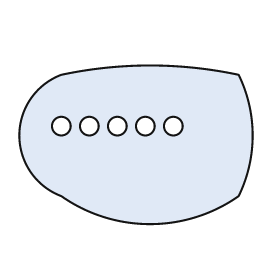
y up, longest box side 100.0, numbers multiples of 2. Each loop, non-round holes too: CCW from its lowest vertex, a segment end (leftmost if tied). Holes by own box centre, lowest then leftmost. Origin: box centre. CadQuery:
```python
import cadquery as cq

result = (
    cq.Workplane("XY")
    .moveTo(-32.0, -22.0)
    .threePointArc((6.0, -34.0), (44.0, -22.0))
    .threePointArc((50.0, 4.0), (44.0, 30.0))
    .threePointArc((6.0, 34.0), (-32.0, 30.0))
    .threePointArc((-50.0, 4.0), (-32.0, -22.0))
    .close()
    .moveTo(-32.0, 8.0)
    .circle(4.0)
    .moveTo(-20.0, 8.0)
    .circle(4.0)
    .moveTo(-8.0, 8.0)
    .circle(4.0)
    .moveTo(4.0, 8.0)
    .circle(4.0)
    .moveTo(16.0, 8.0)
    .circle(4.0)
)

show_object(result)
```